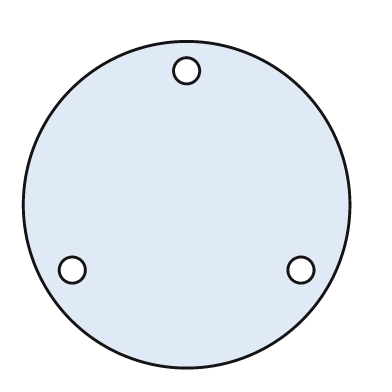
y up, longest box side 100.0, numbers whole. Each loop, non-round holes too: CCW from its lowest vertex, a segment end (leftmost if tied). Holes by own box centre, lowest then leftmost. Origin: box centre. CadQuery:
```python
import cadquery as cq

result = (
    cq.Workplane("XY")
    .moveTo(0.0, 0.0)
    .circle(50.0)
    .moveTo(-35.0, -20.0)
    .circle(4.0)
    .moveTo(35.0, -20.0)
    .circle(4.0)
    .moveTo(0.0, 41.0)
    .circle(4.0)
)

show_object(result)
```